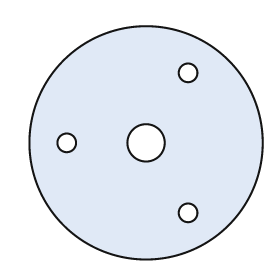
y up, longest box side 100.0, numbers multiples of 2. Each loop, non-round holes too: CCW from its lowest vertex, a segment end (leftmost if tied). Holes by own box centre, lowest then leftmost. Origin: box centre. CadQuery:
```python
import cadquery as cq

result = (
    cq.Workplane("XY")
    .moveTo(0.0, 0.0)
    .circle(50.0)
    .moveTo(18.0, -30.0)
    .circle(4.0)
    .moveTo(-34.0, 0.0)
    .circle(4.0)
    .moveTo(0.0, 0.0)
    .circle(8.0)
    .moveTo(18.0, 30.0)
    .circle(4.0)
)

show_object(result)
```